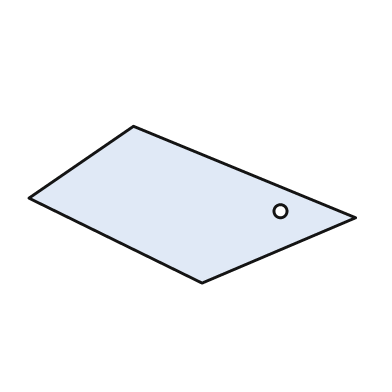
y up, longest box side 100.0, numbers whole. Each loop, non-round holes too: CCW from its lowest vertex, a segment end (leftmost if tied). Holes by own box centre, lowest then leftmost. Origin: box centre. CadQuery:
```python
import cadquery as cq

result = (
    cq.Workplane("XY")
    .moveTo(3.0, -24.0)
    .lineTo(50.0, -4.0)
    .lineTo(-18.0, 24.0)
    .lineTo(-50.0, 2.0)
    .close()
    .moveTo(27.0, -2.0)
    .circle(2.0)
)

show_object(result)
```